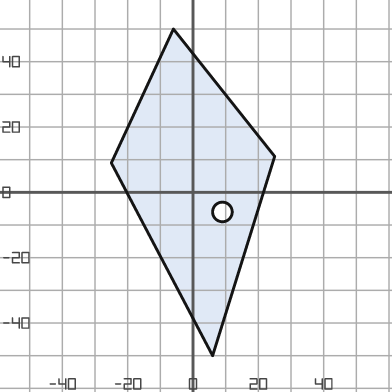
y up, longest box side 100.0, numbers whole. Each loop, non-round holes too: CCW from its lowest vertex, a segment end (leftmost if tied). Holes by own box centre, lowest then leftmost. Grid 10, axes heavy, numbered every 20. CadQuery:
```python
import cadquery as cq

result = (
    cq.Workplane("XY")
    .moveTo(6.0, -50.0)
    .lineTo(25.0, 11.0)
    .lineTo(-6.0, 50.0)
    .lineTo(-25.0, 9.0)
    .close()
    .moveTo(9.0, -6.0)
    .circle(3.0)
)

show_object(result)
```